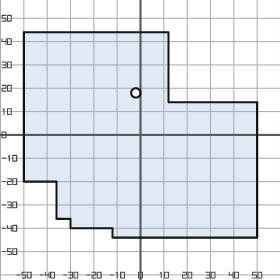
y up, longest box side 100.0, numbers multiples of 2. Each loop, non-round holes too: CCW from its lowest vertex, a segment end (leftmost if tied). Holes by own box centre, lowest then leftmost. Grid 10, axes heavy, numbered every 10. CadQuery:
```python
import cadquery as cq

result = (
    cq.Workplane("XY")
    .moveTo(-12.0, -44.0)
    .lineTo(50.0, -44.0)
    .lineTo(50.0, 14.0)
    .lineTo(12.0, 14.0)
    .lineTo(12.0, 44.0)
    .lineTo(-50.0, 44.0)
    .lineTo(-50.0, -20.0)
    .lineTo(-36.0, -20.0)
    .lineTo(-36.0, -36.0)
    .lineTo(-30.0, -36.0)
    .lineTo(-30.0, -40.0)
    .lineTo(-12.0, -40.0)
    .close()
    .moveTo(-2.0, 18.0)
    .circle(2.0)
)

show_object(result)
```